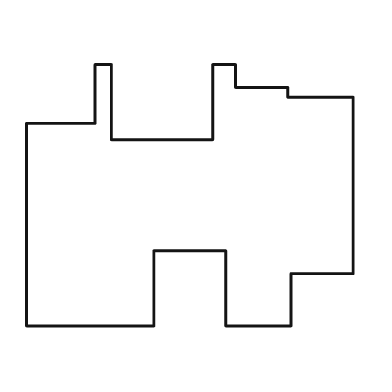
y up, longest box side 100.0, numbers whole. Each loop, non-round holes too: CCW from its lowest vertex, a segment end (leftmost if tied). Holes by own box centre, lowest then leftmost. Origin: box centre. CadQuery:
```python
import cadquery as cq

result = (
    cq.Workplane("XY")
    .moveTo(-50.0, -40.0)
    .lineTo(-11.0, -40.0)
    .lineTo(-11.0, -17.0)
    .lineTo(11.0, -17.0)
    .lineTo(11.0, -40.0)
    .lineTo(31.0, -40.0)
    .lineTo(31.0, -24.0)
    .lineTo(50.0, -24.0)
    .lineTo(50.0, 30.0)
    .lineTo(30.0, 30.0)
    .lineTo(30.0, 33.0)
    .lineTo(14.0, 33.0)
    .lineTo(14.0, 40.0)
    .lineTo(7.0, 40.0)
    .lineTo(7.0, 17.0)
    .lineTo(-24.0, 17.0)
    .lineTo(-24.0, 40.0)
    .lineTo(-29.0, 40.0)
    .lineTo(-29.0, 22.0)
    .lineTo(-50.0, 22.0)
    .close()
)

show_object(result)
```